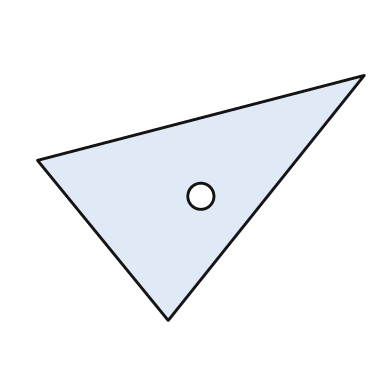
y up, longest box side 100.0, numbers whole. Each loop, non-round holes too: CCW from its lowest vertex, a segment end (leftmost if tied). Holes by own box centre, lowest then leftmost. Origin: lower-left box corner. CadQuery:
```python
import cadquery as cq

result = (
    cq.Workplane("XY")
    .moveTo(40.0, 0.0)
    .lineTo(100.0, 75.0)
    .lineTo(0.0, 49.0)
    .close()
    .moveTo(50.0, 38.0)
    .circle(4.0)
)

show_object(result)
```